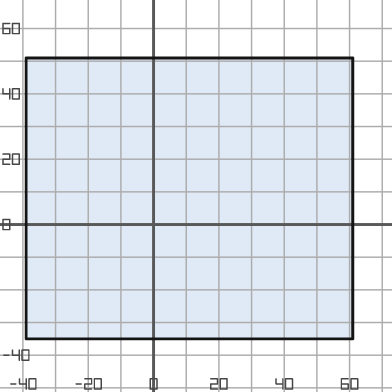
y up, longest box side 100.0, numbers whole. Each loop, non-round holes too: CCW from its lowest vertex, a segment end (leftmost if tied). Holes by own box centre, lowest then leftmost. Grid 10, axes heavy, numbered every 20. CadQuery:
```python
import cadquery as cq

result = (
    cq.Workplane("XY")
    .moveTo(-39.0, -35.0)
    .lineTo(61.0, -35.0)
    .lineTo(61.0, 51.0)
    .lineTo(-39.0, 51.0)
    .close()
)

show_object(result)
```